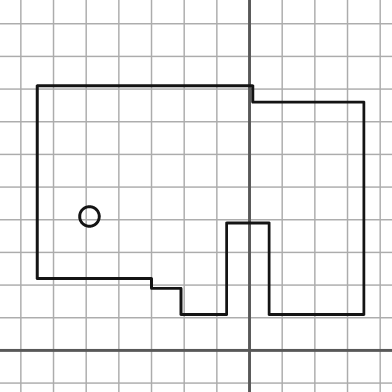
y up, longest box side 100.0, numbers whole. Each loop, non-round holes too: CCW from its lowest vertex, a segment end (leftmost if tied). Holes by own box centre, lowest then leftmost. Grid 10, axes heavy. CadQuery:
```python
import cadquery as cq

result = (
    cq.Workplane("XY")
    .moveTo(-21.0, 11.0)
    .lineTo(-7.0, 11.0)
    .lineTo(-7.0, 39.0)
    .lineTo(6.0, 39.0)
    .lineTo(6.0, 11.0)
    .lineTo(35.0, 11.0)
    .lineTo(35.0, 76.0)
    .lineTo(1.0, 76.0)
    .lineTo(1.0, 81.0)
    .lineTo(-65.0, 81.0)
    .lineTo(-65.0, 22.0)
    .lineTo(-30.0, 22.0)
    .lineTo(-30.0, 19.0)
    .lineTo(-21.0, 19.0)
    .close()
    .moveTo(-49.0, 41.0)
    .circle(3.0)
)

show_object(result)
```